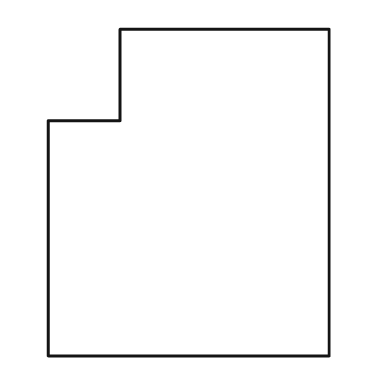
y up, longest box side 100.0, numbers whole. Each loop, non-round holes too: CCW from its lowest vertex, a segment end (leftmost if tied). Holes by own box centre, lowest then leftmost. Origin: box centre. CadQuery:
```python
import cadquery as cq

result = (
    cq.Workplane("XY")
    .moveTo(-43.0, -50.0)
    .lineTo(43.0, -50.0)
    .lineTo(43.0, 50.0)
    .lineTo(-21.0, 50.0)
    .lineTo(-21.0, 22.0)
    .lineTo(-43.0, 22.0)
    .close()
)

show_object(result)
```